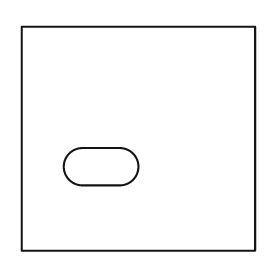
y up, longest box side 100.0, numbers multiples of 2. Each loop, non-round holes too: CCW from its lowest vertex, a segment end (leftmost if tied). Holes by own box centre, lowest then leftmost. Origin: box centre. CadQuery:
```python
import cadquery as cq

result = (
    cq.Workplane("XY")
    .moveTo(-50.0, -48.0)
    .lineTo(50.0, -48.0)
    .lineTo(50.0, 48.0)
    .lineTo(-50.0, 48.0)
    .close()
    .moveTo(-24.0, -20.0)
    .lineTo(-8.0, -20.0)
    .threePointArc((0.0, -12.0), (-8.0, -4.0))
    .lineTo(-24.0, -4.0)
    .threePointArc((-32.0, -12.0), (-24.0, -20.0))
    .close()
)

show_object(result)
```